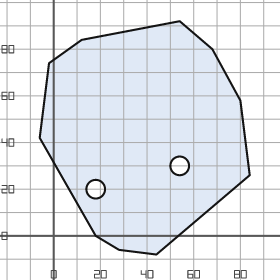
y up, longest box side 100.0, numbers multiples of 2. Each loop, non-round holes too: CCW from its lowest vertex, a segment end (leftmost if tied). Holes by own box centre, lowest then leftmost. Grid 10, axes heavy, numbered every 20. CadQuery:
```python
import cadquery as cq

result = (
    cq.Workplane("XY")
    .moveTo(44.0, -8.0)
    .lineTo(84.0, 26.0)
    .lineTo(80.0, 58.0)
    .lineTo(68.0, 80.0)
    .lineTo(54.0, 92.0)
    .lineTo(12.0, 84.0)
    .lineTo(-2.0, 74.0)
    .lineTo(-6.0, 42.0)
    .lineTo(18.0, 0.0)
    .lineTo(28.0, -6.0)
    .close()
    .moveTo(18.0, 20.0)
    .circle(4.0)
    .moveTo(54.0, 30.0)
    .circle(4.0)
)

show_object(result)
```